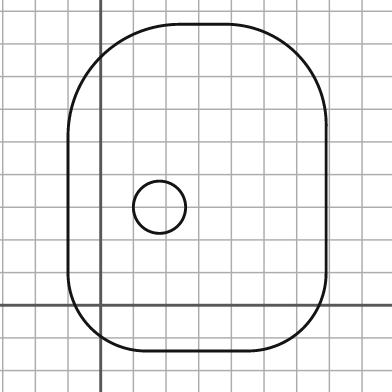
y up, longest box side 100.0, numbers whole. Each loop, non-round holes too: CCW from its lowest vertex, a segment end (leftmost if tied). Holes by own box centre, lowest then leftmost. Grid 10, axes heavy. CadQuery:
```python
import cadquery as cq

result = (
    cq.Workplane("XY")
    .moveTo(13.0, -14.0)
    .lineTo(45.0, -14.0)
    .threePointArc((62.0, -7.0), (69.0, 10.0))
    .lineTo(69.0, 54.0)
    .threePointArc((60.0, 77.0), (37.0, 86.0))
    .lineTo(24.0, 86.0)
    .threePointArc((0.0, 76.0), (-10.0, 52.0))
    .lineTo(-10.0, 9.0)
    .threePointArc((-3.0, -7.0), (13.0, -14.0))
    .close()
    .moveTo(18.0, 30.0)
    .circle(8.0)
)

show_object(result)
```